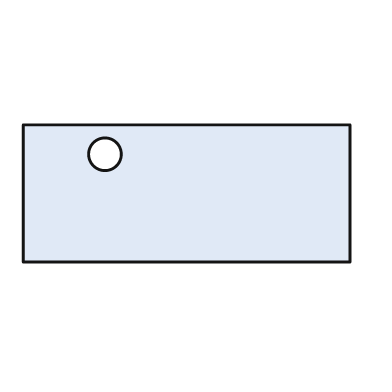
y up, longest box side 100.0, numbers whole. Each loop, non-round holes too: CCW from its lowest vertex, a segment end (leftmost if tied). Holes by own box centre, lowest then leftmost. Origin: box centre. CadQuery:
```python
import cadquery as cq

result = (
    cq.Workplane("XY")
    .moveTo(-50.0, -21.0)
    .lineTo(50.0, -21.0)
    .lineTo(50.0, 21.0)
    .lineTo(-50.0, 21.0)
    .close()
    .moveTo(-25.0, 12.0)
    .circle(5.0)
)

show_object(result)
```